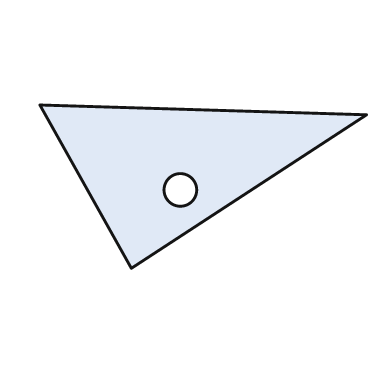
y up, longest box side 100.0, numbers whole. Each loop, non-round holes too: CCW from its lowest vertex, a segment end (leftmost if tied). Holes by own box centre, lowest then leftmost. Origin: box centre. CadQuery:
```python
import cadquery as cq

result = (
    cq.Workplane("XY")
    .moveTo(-22.0, -25.0)
    .lineTo(50.0, 22.0)
    .lineTo(-50.0, 25.0)
    .close()
    .moveTo(-7.0, -1.0)
    .circle(5.0)
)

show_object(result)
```